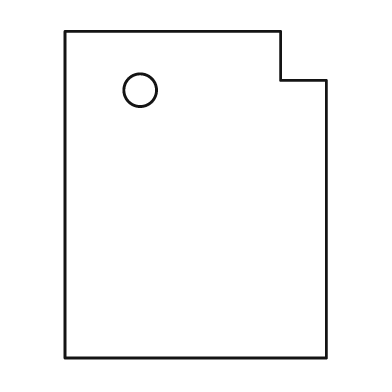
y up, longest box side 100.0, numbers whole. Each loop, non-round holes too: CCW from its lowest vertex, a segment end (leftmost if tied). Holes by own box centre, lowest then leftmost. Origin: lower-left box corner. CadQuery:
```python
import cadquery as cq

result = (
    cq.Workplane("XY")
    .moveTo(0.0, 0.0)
    .lineTo(80.0, 0.0)
    .lineTo(80.0, 85.0)
    .lineTo(66.0, 85.0)
    .lineTo(66.0, 100.0)
    .lineTo(0.0, 100.0)
    .close()
    .moveTo(23.0, 82.0)
    .circle(5.0)
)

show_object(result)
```